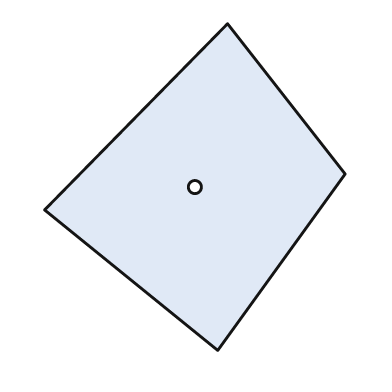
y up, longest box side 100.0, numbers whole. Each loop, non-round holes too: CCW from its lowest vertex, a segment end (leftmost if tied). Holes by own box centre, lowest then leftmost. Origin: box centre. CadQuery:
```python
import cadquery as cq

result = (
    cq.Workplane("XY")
    .moveTo(7.0, -50.0)
    .lineTo(46.0, 4.0)
    .lineTo(10.0, 50.0)
    .lineTo(-46.0, -7.0)
    .close()
    .moveTo(0.0, 0.0)
    .circle(2.0)
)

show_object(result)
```